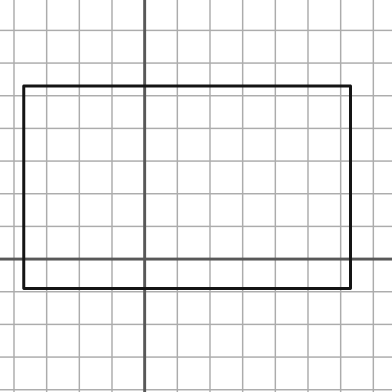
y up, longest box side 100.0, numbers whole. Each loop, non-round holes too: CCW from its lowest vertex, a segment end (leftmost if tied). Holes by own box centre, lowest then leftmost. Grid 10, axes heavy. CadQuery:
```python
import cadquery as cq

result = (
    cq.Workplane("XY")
    .moveTo(-37.0, -9.0)
    .lineTo(63.0, -9.0)
    .lineTo(63.0, 53.0)
    .lineTo(-37.0, 53.0)
    .close()
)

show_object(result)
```